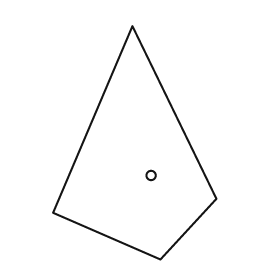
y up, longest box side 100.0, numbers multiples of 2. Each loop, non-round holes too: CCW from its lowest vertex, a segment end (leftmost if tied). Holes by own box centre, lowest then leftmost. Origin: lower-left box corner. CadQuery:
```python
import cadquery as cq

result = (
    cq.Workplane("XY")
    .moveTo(46.0, 0.0)
    .lineTo(70.0, 26.0)
    .lineTo(34.0, 100.0)
    .lineTo(0.0, 20.0)
    .close()
    .moveTo(42.0, 36.0)
    .circle(2.0)
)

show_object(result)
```